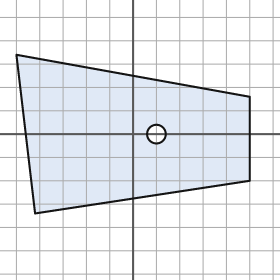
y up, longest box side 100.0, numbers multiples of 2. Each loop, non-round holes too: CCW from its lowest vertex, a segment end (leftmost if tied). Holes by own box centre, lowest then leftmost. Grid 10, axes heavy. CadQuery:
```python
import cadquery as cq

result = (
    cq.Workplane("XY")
    .moveTo(-42.0, -34.0)
    .lineTo(50.0, -20.0)
    .lineTo(50.0, 16.0)
    .lineTo(-50.0, 34.0)
    .close()
    .moveTo(10.0, 0.0)
    .circle(4.0)
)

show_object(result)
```